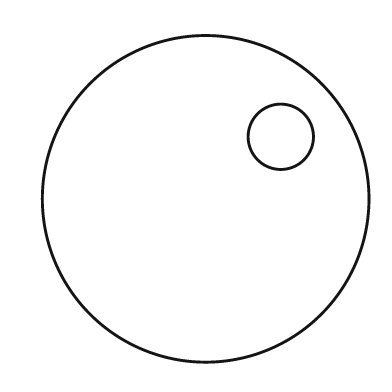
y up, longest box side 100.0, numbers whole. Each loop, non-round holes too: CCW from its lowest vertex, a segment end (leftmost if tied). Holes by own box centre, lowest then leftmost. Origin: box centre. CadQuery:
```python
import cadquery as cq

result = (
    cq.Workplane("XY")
    .moveTo(0.0, 0.0)
    .circle(50.0)
    .moveTo(23.0, 19.0)
    .circle(10.0)
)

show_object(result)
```